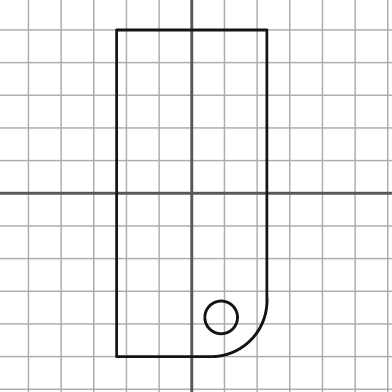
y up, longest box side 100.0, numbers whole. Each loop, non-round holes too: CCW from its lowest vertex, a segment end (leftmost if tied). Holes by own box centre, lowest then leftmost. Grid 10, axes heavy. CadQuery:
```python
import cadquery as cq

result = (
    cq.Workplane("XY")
    .moveTo(-23.0, -50.0)
    .lineTo(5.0, -50.0)
    .threePointArc((18.0, -45.0), (23.0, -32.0))
    .lineTo(23.0, 50.0)
    .lineTo(-23.0, 50.0)
    .close()
    .moveTo(9.0, -38.0)
    .circle(5.0)
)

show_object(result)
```